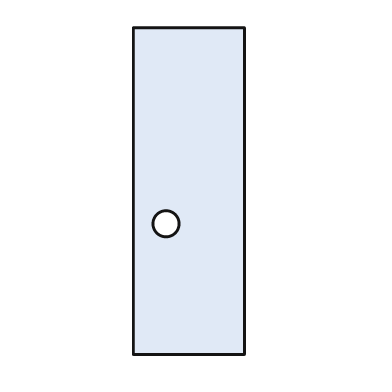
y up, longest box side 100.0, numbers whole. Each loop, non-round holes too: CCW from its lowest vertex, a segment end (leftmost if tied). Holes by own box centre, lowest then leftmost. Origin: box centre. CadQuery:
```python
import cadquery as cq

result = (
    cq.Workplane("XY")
    .moveTo(-17.0, -50.0)
    .lineTo(17.0, -50.0)
    .lineTo(17.0, 50.0)
    .lineTo(-17.0, 50.0)
    .close()
    .moveTo(-7.0, -10.0)
    .circle(4.0)
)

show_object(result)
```